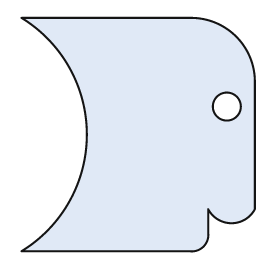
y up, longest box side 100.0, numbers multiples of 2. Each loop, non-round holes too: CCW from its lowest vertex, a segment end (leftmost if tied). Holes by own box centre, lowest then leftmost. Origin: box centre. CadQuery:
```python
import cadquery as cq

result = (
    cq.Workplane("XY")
    .moveTo(-50.0, -50.0)
    .lineTo(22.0, -50.0)
    .threePointArc((28.0, -48.0), (30.0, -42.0))
    .lineTo(30.0, -32.0)
    .threePointArc((40.0, -38.0), (50.0, -32.0))
    .lineTo(50.0, 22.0)
    .threePointArc((42.0, 42.0), (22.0, 50.0))
    .lineTo(-50.0, 50.0)
    .threePointArc((-22.0, 0.0), (-50.0, -50.0))
    .close()
    .moveTo(38.0, 12.0)
    .circle(6.0)
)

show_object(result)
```